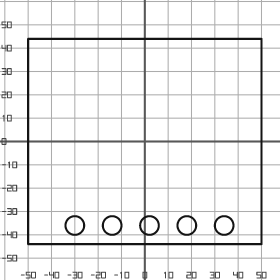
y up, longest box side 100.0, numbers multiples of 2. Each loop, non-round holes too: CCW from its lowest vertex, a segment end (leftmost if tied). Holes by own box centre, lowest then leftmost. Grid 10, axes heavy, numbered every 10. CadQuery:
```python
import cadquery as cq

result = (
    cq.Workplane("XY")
    .moveTo(-50.0, -44.0)
    .lineTo(50.0, -44.0)
    .lineTo(50.0, 44.0)
    .lineTo(-50.0, 44.0)
    .close()
    .moveTo(-30.0, -36.0)
    .circle(4.0)
    .moveTo(-14.0, -36.0)
    .circle(4.0)
    .moveTo(2.0, -36.0)
    .circle(4.0)
    .moveTo(18.0, -36.0)
    .circle(4.0)
    .moveTo(34.0, -36.0)
    .circle(4.0)
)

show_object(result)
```